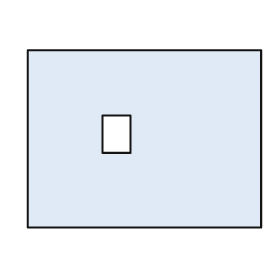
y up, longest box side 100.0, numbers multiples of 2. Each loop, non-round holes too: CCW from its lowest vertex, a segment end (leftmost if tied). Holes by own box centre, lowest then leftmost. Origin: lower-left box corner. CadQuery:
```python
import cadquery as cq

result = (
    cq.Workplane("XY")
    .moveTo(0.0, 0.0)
    .lineTo(100.0, 0.0)
    .lineTo(100.0, 76.0)
    .lineTo(0.0, 76.0)
    .close()
    .moveTo(32.0, 32.0)
    .lineTo(44.0, 32.0)
    .lineTo(44.0, 48.0)
    .lineTo(32.0, 48.0)
    .close()
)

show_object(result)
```